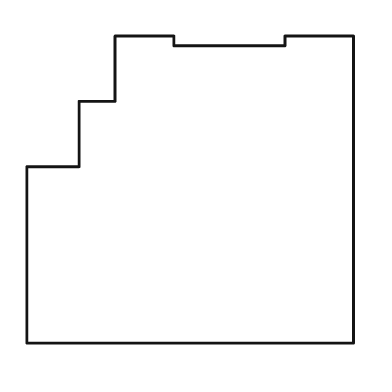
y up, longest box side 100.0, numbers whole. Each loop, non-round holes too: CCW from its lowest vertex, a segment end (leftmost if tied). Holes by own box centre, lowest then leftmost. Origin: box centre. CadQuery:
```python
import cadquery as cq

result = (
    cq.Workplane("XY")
    .moveTo(-50.0, -47.0)
    .lineTo(50.0, -47.0)
    .lineTo(50.0, 47.0)
    .lineTo(29.0, 47.0)
    .lineTo(29.0, 44.0)
    .lineTo(-5.0, 44.0)
    .lineTo(-5.0, 47.0)
    .lineTo(-23.0, 47.0)
    .lineTo(-23.0, 27.0)
    .lineTo(-34.0, 27.0)
    .lineTo(-34.0, 7.0)
    .lineTo(-50.0, 7.0)
    .close()
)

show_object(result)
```